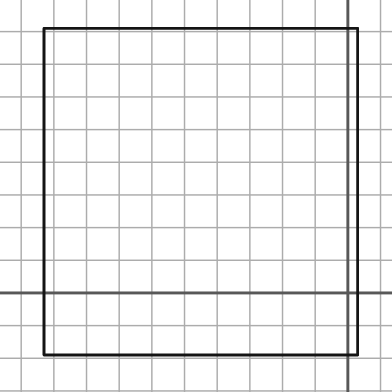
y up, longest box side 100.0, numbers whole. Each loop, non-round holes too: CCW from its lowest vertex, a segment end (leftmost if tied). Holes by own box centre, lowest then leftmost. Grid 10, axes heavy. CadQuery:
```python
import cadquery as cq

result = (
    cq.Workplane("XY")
    .moveTo(-93.0, -19.0)
    .lineTo(3.0, -19.0)
    .lineTo(3.0, 81.0)
    .lineTo(-93.0, 81.0)
    .close()
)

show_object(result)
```